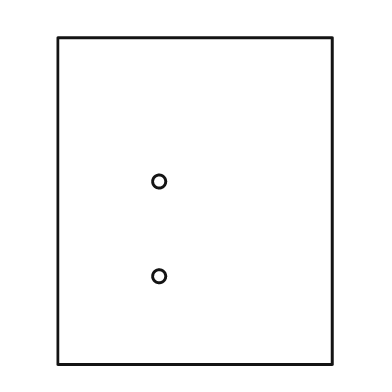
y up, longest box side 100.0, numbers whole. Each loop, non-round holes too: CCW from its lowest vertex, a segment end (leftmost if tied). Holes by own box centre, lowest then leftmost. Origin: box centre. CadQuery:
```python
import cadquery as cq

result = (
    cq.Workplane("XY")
    .moveTo(-42.0, -50.0)
    .lineTo(42.0, -50.0)
    .lineTo(42.0, 50.0)
    .lineTo(-42.0, 50.0)
    .close()
    .moveTo(-11.0, -23.0)
    .circle(2.0)
    .moveTo(-11.0, 6.0)
    .circle(2.0)
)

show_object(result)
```